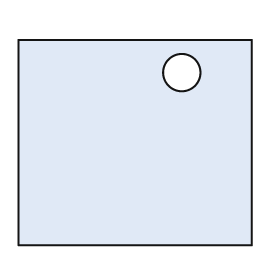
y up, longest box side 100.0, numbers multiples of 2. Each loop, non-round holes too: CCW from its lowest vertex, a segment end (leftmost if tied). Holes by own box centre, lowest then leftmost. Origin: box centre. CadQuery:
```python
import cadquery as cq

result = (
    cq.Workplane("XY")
    .moveTo(-50.0, -44.0)
    .lineTo(50.0, -44.0)
    .lineTo(50.0, 44.0)
    .lineTo(-50.0, 44.0)
    .close()
    .moveTo(20.0, 30.0)
    .circle(8.0)
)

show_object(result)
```